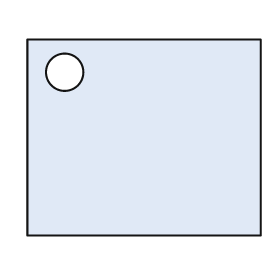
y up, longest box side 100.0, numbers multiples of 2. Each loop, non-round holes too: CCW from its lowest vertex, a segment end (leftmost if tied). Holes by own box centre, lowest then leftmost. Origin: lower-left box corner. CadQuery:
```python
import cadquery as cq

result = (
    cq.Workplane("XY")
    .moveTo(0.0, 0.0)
    .lineTo(100.0, 0.0)
    .lineTo(100.0, 84.0)
    .lineTo(0.0, 84.0)
    .close()
    .moveTo(16.0, 70.0)
    .circle(8.0)
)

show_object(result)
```